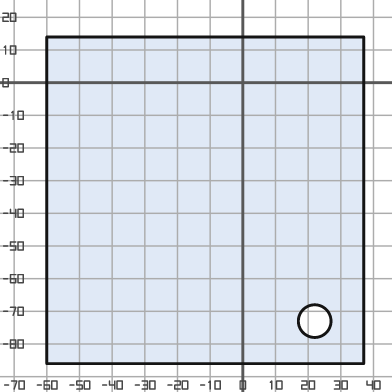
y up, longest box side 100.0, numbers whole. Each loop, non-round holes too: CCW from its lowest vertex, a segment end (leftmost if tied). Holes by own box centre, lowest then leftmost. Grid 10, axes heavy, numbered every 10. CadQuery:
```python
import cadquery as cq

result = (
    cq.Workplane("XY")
    .moveTo(-60.0, -86.0)
    .lineTo(37.0, -86.0)
    .lineTo(37.0, 14.0)
    .lineTo(-60.0, 14.0)
    .close()
    .moveTo(22.0, -73.0)
    .circle(5.0)
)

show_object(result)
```